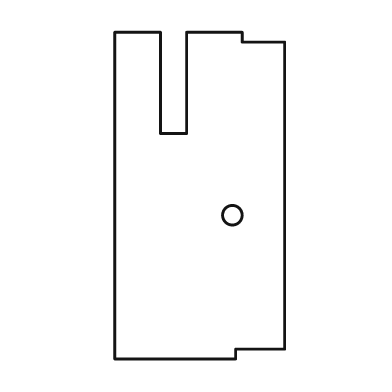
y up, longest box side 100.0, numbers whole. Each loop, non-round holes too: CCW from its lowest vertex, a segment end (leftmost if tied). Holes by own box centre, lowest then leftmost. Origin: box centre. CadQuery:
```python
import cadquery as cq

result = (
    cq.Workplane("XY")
    .moveTo(-26.0, -50.0)
    .lineTo(11.0, -50.0)
    .lineTo(11.0, -47.0)
    .lineTo(26.0, -47.0)
    .lineTo(26.0, 47.0)
    .lineTo(13.0, 47.0)
    .lineTo(13.0, 50.0)
    .lineTo(-4.0, 50.0)
    .lineTo(-4.0, 19.0)
    .lineTo(-12.0, 19.0)
    .lineTo(-12.0, 50.0)
    .lineTo(-26.0, 50.0)
    .close()
    .moveTo(10.0, -6.0)
    .circle(3.0)
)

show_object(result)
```